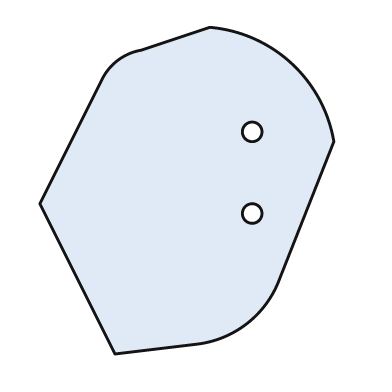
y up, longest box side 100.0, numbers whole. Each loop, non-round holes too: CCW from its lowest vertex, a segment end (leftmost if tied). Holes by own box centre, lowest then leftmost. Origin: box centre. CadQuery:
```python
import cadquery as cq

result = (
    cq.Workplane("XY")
    .moveTo(-22.0, -50.0)
    .lineTo(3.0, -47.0)
    .threePointArc((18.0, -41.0), (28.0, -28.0))
    .lineTo(45.0, 15.0)
    .threePointArc((32.0, 39.0), (7.0, 50.0))
    .lineTo(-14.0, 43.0)
    .threePointArc((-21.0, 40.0), (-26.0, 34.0))
    .lineTo(-45.0, -4.0)
    .close()
    .moveTo(20.0, -7.0)
    .circle(3.0)
    .moveTo(20.0, 18.0)
    .circle(3.0)
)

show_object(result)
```